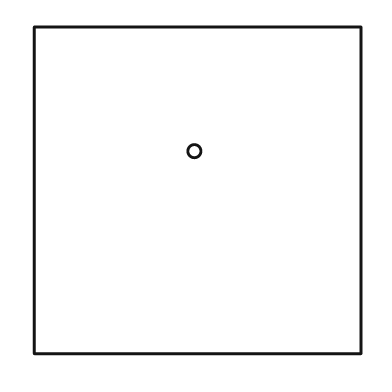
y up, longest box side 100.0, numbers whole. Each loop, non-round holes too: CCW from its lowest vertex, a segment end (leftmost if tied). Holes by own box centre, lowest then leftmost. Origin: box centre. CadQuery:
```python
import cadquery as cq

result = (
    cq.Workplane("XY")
    .moveTo(-50.0, -50.0)
    .lineTo(50.0, -50.0)
    .lineTo(50.0, 50.0)
    .lineTo(-50.0, 50.0)
    .close()
    .moveTo(-1.0, 12.0)
    .circle(2.0)
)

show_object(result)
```